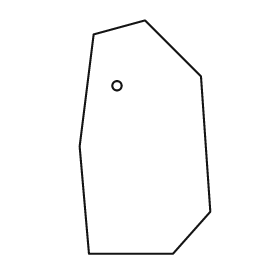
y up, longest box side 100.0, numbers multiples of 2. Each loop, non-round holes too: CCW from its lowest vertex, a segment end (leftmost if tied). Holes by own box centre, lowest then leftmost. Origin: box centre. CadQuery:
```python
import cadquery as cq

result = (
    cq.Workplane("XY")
    .moveTo(-24.0, -50.0)
    .lineTo(12.0, -50.0)
    .lineTo(28.0, -32.0)
    .lineTo(24.0, 26.0)
    .lineTo(0.0, 50.0)
    .lineTo(-22.0, 44.0)
    .lineTo(-28.0, -4.0)
    .close()
    .moveTo(-12.0, 22.0)
    .circle(2.0)
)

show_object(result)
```